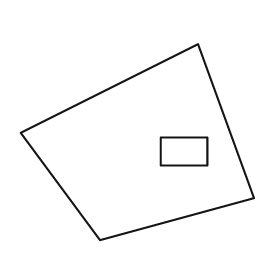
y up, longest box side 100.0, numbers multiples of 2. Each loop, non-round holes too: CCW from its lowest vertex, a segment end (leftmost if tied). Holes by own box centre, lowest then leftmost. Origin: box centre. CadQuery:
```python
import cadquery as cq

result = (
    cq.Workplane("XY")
    .moveTo(-16.0, -42.0)
    .lineTo(50.0, -24.0)
    .lineTo(26.0, 42.0)
    .lineTo(-50.0, 4.0)
    .close()
    .moveTo(10.0, -10.0)
    .lineTo(30.0, -10.0)
    .lineTo(30.0, 2.0)
    .lineTo(10.0, 2.0)
    .close()
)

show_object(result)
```